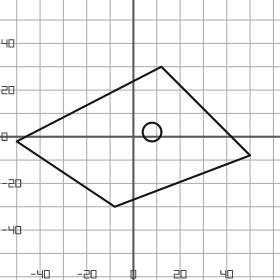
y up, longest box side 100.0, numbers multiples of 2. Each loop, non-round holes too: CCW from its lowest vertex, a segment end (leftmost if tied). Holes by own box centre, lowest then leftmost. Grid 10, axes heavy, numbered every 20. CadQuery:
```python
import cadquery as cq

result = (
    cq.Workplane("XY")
    .moveTo(-8.0, -30.0)
    .lineTo(50.0, -8.0)
    .lineTo(12.0, 30.0)
    .lineTo(-50.0, -2.0)
    .close()
    .moveTo(8.0, 2.0)
    .circle(4.0)
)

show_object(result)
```